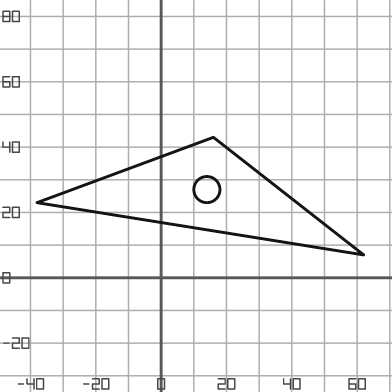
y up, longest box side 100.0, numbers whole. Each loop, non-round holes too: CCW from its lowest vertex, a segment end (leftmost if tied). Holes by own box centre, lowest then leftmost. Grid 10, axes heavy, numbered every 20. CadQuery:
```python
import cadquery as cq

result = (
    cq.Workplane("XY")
    .moveTo(62.0, 7.0)
    .lineTo(16.0, 43.0)
    .lineTo(-38.0, 23.0)
    .close()
    .moveTo(14.0, 27.0)
    .circle(4.0)
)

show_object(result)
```